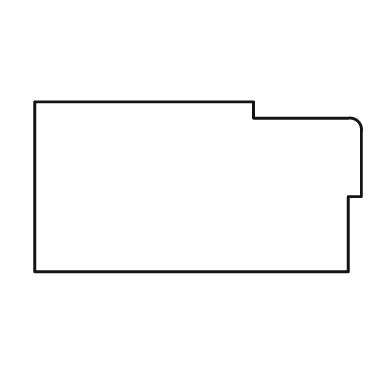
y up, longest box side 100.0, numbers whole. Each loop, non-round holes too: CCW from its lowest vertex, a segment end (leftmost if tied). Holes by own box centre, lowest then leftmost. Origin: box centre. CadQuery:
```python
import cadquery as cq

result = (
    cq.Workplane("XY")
    .moveTo(-50.0, -26.0)
    .lineTo(46.0, -26.0)
    .lineTo(46.0, -3.0)
    .lineTo(50.0, -3.0)
    .lineTo(50.0, 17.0)
    .threePointArc((49.0, 20.0), (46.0, 21.0))
    .lineTo(17.0, 21.0)
    .lineTo(17.0, 26.0)
    .lineTo(-50.0, 26.0)
    .close()
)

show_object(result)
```